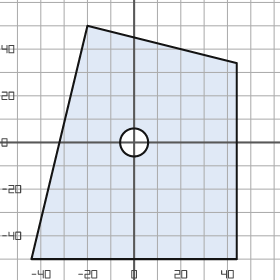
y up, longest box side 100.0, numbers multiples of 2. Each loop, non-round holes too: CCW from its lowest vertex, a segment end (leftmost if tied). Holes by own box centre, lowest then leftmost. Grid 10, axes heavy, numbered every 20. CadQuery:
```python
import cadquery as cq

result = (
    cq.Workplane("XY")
    .moveTo(-44.0, -50.0)
    .lineTo(44.0, -50.0)
    .lineTo(44.0, 34.0)
    .lineTo(-20.0, 50.0)
    .close()
    .moveTo(0.0, 0.0)
    .circle(6.0)
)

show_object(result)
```